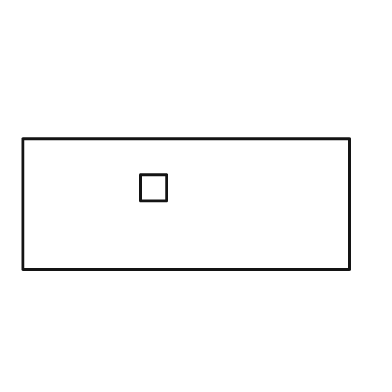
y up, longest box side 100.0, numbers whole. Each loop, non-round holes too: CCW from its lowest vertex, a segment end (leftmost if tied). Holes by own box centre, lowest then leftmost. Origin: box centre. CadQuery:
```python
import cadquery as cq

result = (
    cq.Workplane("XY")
    .moveTo(-50.0, -20.0)
    .lineTo(50.0, -20.0)
    .lineTo(50.0, 20.0)
    .lineTo(-50.0, 20.0)
    .close()
    .moveTo(-14.0, 1.0)
    .lineTo(-6.0, 1.0)
    .lineTo(-6.0, 9.0)
    .lineTo(-14.0, 9.0)
    .close()
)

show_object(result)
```